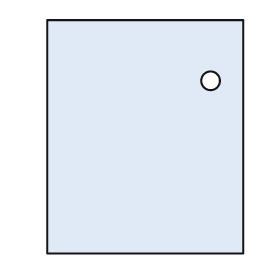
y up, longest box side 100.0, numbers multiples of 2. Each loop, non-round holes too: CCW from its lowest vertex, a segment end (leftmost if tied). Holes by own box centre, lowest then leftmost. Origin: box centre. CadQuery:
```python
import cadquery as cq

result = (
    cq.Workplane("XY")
    .moveTo(-42.0, -50.0)
    .lineTo(42.0, -50.0)
    .lineTo(42.0, 50.0)
    .lineTo(-42.0, 50.0)
    .close()
    .moveTo(28.0, 24.0)
    .circle(4.0)
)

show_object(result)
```